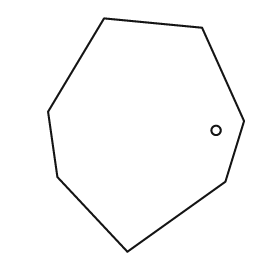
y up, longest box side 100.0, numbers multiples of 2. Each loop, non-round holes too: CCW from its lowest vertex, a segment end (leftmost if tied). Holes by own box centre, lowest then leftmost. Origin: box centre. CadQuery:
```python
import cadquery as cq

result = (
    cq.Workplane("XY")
    .moveTo(-8.0, -50.0)
    .lineTo(34.0, -20.0)
    .lineTo(42.0, 6.0)
    .lineTo(24.0, 46.0)
    .lineTo(-18.0, 50.0)
    .lineTo(-42.0, 10.0)
    .lineTo(-38.0, -18.0)
    .close()
    .moveTo(30.0, 2.0)
    .circle(2.0)
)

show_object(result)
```